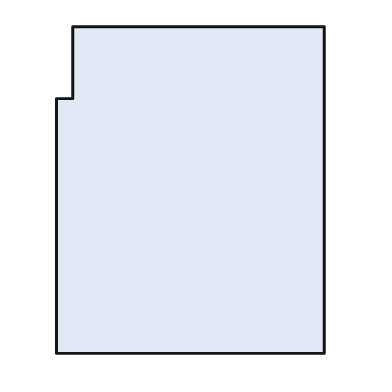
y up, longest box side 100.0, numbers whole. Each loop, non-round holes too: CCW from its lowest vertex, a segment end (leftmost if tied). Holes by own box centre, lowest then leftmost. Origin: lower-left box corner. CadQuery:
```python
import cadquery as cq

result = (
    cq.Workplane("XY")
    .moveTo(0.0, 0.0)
    .lineTo(82.0, 0.0)
    .lineTo(82.0, 100.0)
    .lineTo(5.0, 100.0)
    .lineTo(5.0, 78.0)
    .lineTo(0.0, 78.0)
    .close()
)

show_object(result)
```